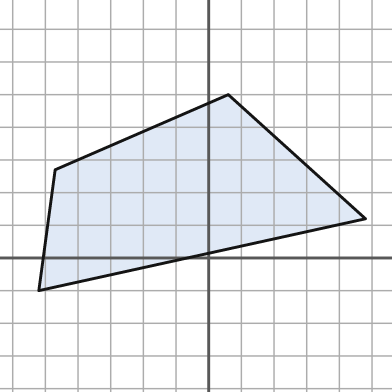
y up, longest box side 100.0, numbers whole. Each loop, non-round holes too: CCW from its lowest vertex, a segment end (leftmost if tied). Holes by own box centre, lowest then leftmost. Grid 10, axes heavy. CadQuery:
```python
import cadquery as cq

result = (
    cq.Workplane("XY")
    .moveTo(-52.0, -10.0)
    .lineTo(48.0, 12.0)
    .lineTo(6.0, 50.0)
    .lineTo(-47.0, 27.0)
    .close()
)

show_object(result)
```